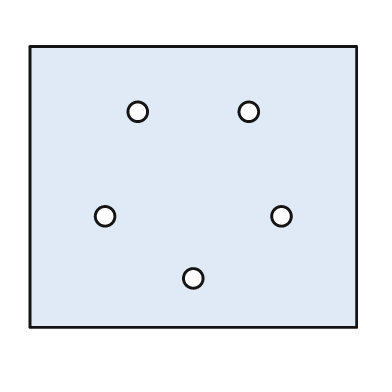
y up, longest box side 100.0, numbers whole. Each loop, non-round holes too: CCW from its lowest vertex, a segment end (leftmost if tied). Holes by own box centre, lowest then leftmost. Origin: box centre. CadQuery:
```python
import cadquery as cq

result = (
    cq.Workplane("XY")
    .moveTo(-50.0, -43.0)
    .lineTo(50.0, -43.0)
    .lineTo(50.0, 43.0)
    .lineTo(-50.0, 43.0)
    .close()
    .moveTo(0.0, -28.0)
    .circle(3.0)
    .moveTo(-27.0, -9.0)
    .circle(3.0)
    .moveTo(27.0, -9.0)
    .circle(3.0)
    .moveTo(-17.0, 23.0)
    .circle(3.0)
    .moveTo(17.0, 23.0)
    .circle(3.0)
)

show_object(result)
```